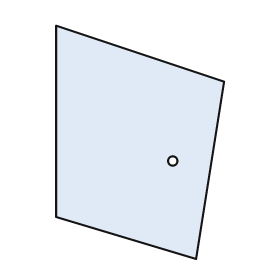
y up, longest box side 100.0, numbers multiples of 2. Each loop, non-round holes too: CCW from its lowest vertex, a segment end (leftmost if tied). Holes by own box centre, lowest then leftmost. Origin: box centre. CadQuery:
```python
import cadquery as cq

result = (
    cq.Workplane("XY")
    .moveTo(24.0, -50.0)
    .lineTo(36.0, 26.0)
    .lineTo(-36.0, 50.0)
    .lineTo(-36.0, -32.0)
    .close()
    .moveTo(14.0, -8.0)
    .circle(2.0)
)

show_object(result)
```